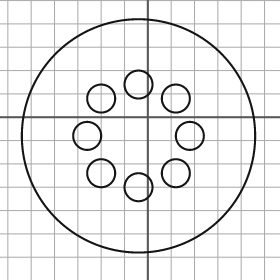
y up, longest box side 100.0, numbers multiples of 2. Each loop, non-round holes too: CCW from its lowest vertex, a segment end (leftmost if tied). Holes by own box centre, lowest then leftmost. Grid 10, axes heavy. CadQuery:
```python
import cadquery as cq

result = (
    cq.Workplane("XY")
    .moveTo(-4.0, -8.0)
    .circle(50.0)
    .moveTo(-4.0, -30.0)
    .circle(6.0)
    .moveTo(-20.0, -24.0)
    .circle(6.0)
    .moveTo(12.0, -24.0)
    .circle(6.0)
    .moveTo(-26.0, -8.0)
    .circle(6.0)
    .moveTo(18.0, -8.0)
    .circle(6.0)
    .moveTo(-20.0, 8.0)
    .circle(6.0)
    .moveTo(12.0, 8.0)
    .circle(6.0)
    .moveTo(-4.0, 14.0)
    .circle(6.0)
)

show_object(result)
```